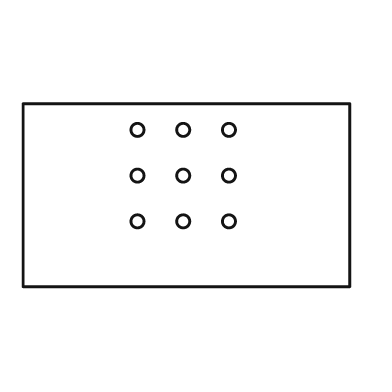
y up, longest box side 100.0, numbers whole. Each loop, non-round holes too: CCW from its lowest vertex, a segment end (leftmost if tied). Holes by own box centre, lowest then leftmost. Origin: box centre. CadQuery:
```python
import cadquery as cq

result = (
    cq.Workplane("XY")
    .moveTo(-50.0, -28.0)
    .lineTo(50.0, -28.0)
    .lineTo(50.0, 28.0)
    .lineTo(-50.0, 28.0)
    .close()
    .moveTo(-15.0, -8.0)
    .circle(2.0)
    .moveTo(-1.0, -8.0)
    .circle(2.0)
    .moveTo(13.0, -8.0)
    .circle(2.0)
    .moveTo(-15.0, 6.0)
    .circle(2.0)
    .moveTo(-1.0, 6.0)
    .circle(2.0)
    .moveTo(13.0, 6.0)
    .circle(2.0)
    .moveTo(-15.0, 20.0)
    .circle(2.0)
    .moveTo(-1.0, 20.0)
    .circle(2.0)
    .moveTo(13.0, 20.0)
    .circle(2.0)
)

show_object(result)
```